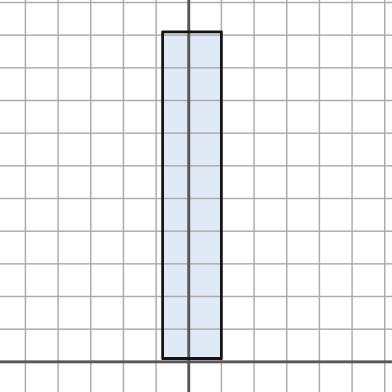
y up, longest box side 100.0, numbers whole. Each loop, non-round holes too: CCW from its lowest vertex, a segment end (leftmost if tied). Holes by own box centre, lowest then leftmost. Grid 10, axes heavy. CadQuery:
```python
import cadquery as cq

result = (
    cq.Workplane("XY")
    .moveTo(-8.0, 1.0)
    .lineTo(10.0, 1.0)
    .lineTo(10.0, 101.0)
    .lineTo(-8.0, 101.0)
    .close()
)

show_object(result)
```